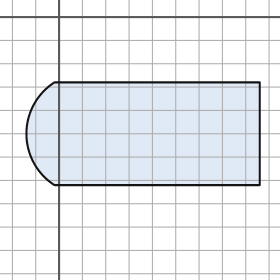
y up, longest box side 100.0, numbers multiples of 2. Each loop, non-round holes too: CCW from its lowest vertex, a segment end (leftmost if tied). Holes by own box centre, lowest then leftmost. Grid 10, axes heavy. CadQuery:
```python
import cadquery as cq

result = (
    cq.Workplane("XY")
    .moveTo(-2.0, -72.0)
    .lineTo(86.0, -72.0)
    .lineTo(86.0, -28.0)
    .lineTo(-2.0, -28.0)
    .threePointArc((-14.0, -50.0), (-2.0, -72.0))
    .close()
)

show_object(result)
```